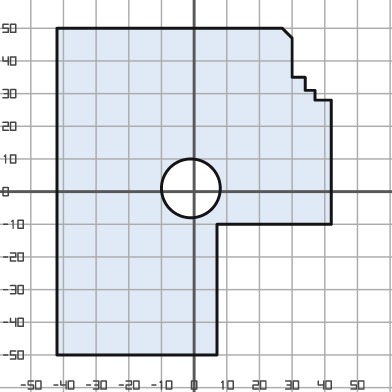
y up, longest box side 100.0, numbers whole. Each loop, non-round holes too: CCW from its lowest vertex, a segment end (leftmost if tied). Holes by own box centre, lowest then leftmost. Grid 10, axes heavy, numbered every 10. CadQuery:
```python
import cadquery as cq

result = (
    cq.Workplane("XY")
    .moveTo(-42.0, -50.0)
    .lineTo(7.0, -50.0)
    .lineTo(7.0, -10.0)
    .lineTo(42.0, -10.0)
    .lineTo(42.0, 28.0)
    .lineTo(37.0, 28.0)
    .lineTo(37.0, 31.0)
    .lineTo(34.0, 31.0)
    .lineTo(34.0, 35.0)
    .lineTo(30.0, 35.0)
    .lineTo(30.0, 47.0)
    .lineTo(27.0, 50.0)
    .lineTo(-42.0, 50.0)
    .close()
    .moveTo(-1.0, 1.0)
    .circle(9.0)
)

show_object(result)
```